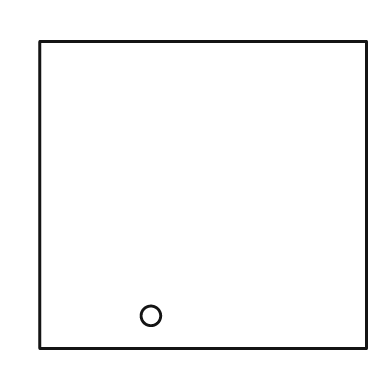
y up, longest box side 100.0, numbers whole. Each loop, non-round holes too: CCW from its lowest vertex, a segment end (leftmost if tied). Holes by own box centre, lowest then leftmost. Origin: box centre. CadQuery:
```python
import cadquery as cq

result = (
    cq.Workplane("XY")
    .moveTo(-50.0, -47.0)
    .lineTo(50.0, -47.0)
    .lineTo(50.0, 47.0)
    .lineTo(-50.0, 47.0)
    .close()
    .moveTo(-16.0, -37.0)
    .circle(3.0)
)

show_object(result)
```